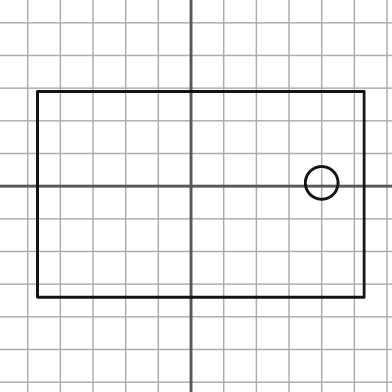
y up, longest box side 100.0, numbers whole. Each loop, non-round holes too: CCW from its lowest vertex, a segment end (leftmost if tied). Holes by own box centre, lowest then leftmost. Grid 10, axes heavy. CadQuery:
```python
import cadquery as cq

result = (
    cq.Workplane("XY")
    .moveTo(-47.0, -34.0)
    .lineTo(53.0, -34.0)
    .lineTo(53.0, 29.0)
    .lineTo(-47.0, 29.0)
    .close()
    .moveTo(40.0, 1.0)
    .circle(5.0)
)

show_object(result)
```